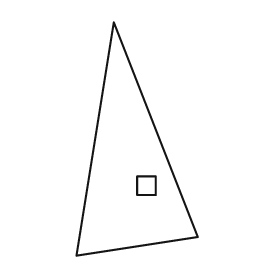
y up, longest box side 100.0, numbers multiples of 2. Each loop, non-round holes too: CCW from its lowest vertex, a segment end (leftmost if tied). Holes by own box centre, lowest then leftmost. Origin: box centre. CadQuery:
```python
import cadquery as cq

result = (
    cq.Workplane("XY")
    .moveTo(-26.0, -50.0)
    .lineTo(26.0, -42.0)
    .lineTo(-10.0, 50.0)
    .close()
    .moveTo(0.0, -24.0)
    .lineTo(8.0, -24.0)
    .lineTo(8.0, -16.0)
    .lineTo(0.0, -16.0)
    .close()
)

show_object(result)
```